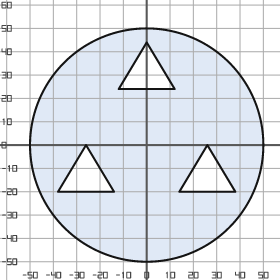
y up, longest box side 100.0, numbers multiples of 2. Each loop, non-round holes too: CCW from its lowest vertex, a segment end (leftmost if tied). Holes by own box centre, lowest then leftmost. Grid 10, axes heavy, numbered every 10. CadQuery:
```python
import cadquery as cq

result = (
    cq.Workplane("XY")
    .moveTo(0.0, 0.0)
    .circle(50.0)
    .moveTo(-38.0, -20.0)
    .lineTo(-14.0, -20.0)
    .lineTo(-26.0, 0.0)
    .close()
    .moveTo(14.0, -20.0)
    .lineTo(38.0, -20.0)
    .lineTo(26.0, 0.0)
    .close()
    .moveTo(-12.0, 24.0)
    .lineTo(12.0, 24.0)
    .lineTo(0.0, 44.0)
    .close()
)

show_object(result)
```